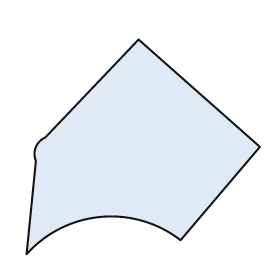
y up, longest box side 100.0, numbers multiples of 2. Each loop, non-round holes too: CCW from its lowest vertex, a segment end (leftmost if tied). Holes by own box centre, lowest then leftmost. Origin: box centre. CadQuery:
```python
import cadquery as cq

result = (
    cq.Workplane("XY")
    .moveTo(-50.0, -46.0)
    .threePointArc((-18.0, -30.0), (16.0, -40.0))
    .lineTo(50.0, 0.0)
    .lineTo(-2.0, 46.0)
    .lineTo(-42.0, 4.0)
    .threePointArc((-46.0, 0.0), (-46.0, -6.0))
    .close()
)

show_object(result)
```